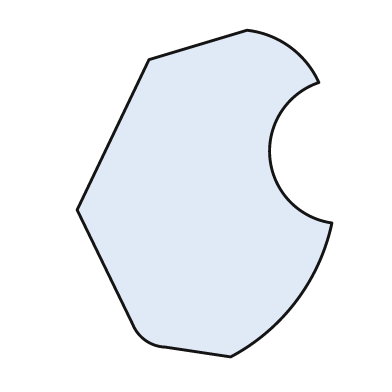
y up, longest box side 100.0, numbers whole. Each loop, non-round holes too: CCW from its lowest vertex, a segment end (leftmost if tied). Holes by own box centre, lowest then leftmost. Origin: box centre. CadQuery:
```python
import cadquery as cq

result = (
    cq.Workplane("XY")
    .moveTo(8.0, -50.0)
    .threePointArc((28.0, -33.0), (39.0, -9.0))
    .threePointArc((20.0, 11.0), (35.0, 34.0))
    .threePointArc((26.0, 45.0), (13.0, 50.0))
    .lineTo(-17.0, 41.0)
    .lineTo(-39.0, -5.0)
    .lineTo(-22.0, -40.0)
    .threePointArc((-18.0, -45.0), (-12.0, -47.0))
    .close()
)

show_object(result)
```